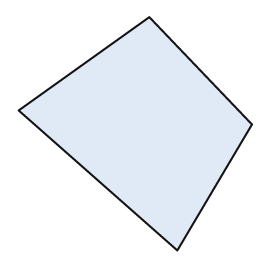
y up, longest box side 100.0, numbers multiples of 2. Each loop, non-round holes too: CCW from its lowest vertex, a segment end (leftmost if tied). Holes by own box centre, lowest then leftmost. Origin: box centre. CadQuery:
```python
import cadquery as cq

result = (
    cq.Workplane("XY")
    .moveTo(18.0, -50.0)
    .lineTo(50.0, 4.0)
    .lineTo(6.0, 50.0)
    .lineTo(-50.0, 10.0)
    .close()
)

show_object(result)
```